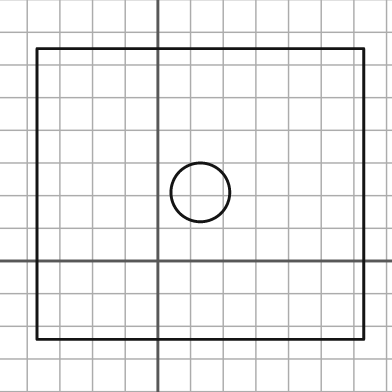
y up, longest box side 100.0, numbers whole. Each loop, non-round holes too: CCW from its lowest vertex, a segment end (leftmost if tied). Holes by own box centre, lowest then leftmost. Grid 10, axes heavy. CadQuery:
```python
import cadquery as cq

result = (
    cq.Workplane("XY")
    .moveTo(-37.0, -24.0)
    .lineTo(63.0, -24.0)
    .lineTo(63.0, 65.0)
    .lineTo(-37.0, 65.0)
    .close()
    .moveTo(13.0, 21.0)
    .circle(9.0)
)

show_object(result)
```